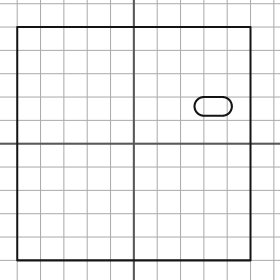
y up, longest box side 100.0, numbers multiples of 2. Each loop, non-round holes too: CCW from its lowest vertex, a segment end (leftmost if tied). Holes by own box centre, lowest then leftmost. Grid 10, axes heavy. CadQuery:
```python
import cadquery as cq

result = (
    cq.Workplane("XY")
    .moveTo(-50.0, -50.0)
    .lineTo(50.0, -50.0)
    .lineTo(50.0, 50.0)
    .lineTo(-50.0, 50.0)
    .close()
    .moveTo(30.0, 12.0)
    .lineTo(38.0, 12.0)
    .threePointArc((42.0, 16.0), (38.0, 20.0))
    .lineTo(30.0, 20.0)
    .threePointArc((26.0, 16.0), (30.0, 12.0))
    .close()
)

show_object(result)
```